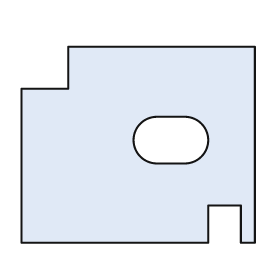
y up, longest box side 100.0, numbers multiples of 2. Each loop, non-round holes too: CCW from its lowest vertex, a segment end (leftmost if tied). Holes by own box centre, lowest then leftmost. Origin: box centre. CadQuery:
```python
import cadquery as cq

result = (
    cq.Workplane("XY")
    .moveTo(-50.0, -42.0)
    .lineTo(30.0, -42.0)
    .lineTo(30.0, -26.0)
    .lineTo(44.0, -26.0)
    .lineTo(44.0, -42.0)
    .lineTo(50.0, -42.0)
    .lineTo(50.0, 42.0)
    .lineTo(-30.0, 42.0)
    .lineTo(-30.0, 24.0)
    .lineTo(-50.0, 24.0)
    .close()
    .moveTo(8.0, -8.0)
    .lineTo(20.0, -8.0)
    .threePointArc((30.0, 2.0), (20.0, 12.0))
    .lineTo(8.0, 12.0)
    .threePointArc((-2.0, 2.0), (8.0, -8.0))
    .close()
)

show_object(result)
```